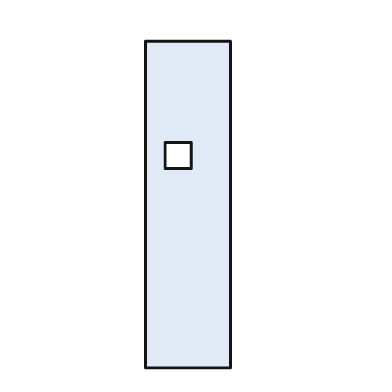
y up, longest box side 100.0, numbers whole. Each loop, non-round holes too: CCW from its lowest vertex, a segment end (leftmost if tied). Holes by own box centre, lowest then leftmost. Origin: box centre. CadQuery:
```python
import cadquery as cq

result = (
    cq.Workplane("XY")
    .moveTo(-13.0, -50.0)
    .lineTo(13.0, -50.0)
    .lineTo(13.0, 50.0)
    .lineTo(-13.0, 50.0)
    .close()
    .moveTo(-7.0, 11.0)
    .lineTo(1.0, 11.0)
    .lineTo(1.0, 19.0)
    .lineTo(-7.0, 19.0)
    .close()
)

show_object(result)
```